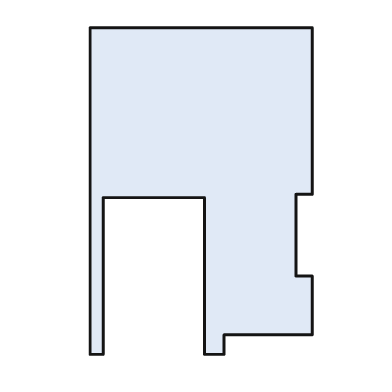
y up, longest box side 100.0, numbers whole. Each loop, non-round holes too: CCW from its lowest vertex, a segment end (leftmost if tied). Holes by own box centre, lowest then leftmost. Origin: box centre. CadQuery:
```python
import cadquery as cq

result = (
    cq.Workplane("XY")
    .moveTo(-34.0, -50.0)
    .lineTo(-30.0, -50.0)
    .lineTo(-30.0, -2.0)
    .lineTo(1.0, -2.0)
    .lineTo(1.0, -50.0)
    .lineTo(7.0, -50.0)
    .lineTo(7.0, -44.0)
    .lineTo(34.0, -44.0)
    .lineTo(34.0, -26.0)
    .lineTo(29.0, -26.0)
    .lineTo(29.0, -1.0)
    .lineTo(34.0, -1.0)
    .lineTo(34.0, 50.0)
    .lineTo(-34.0, 50.0)
    .close()
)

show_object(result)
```